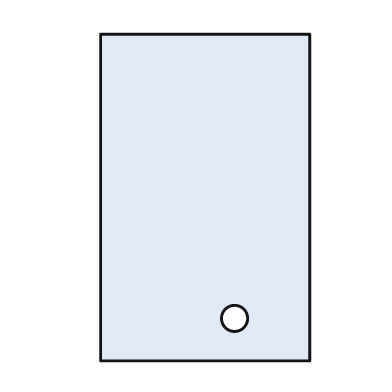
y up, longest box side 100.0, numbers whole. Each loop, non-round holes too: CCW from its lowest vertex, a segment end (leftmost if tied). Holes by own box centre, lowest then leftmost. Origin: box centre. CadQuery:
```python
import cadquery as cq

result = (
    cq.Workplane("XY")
    .moveTo(-32.0, -50.0)
    .lineTo(32.0, -50.0)
    .lineTo(32.0, 50.0)
    .lineTo(-32.0, 50.0)
    .close()
    .moveTo(9.0, -37.0)
    .circle(4.0)
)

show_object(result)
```